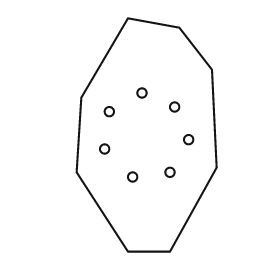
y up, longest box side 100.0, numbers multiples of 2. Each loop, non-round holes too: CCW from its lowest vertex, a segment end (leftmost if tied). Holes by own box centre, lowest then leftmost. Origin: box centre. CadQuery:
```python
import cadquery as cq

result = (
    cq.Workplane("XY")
    .moveTo(-8.0, -50.0)
    .lineTo(10.0, -50.0)
    .lineTo(30.0, -14.0)
    .lineTo(28.0, 28.0)
    .lineTo(14.0, 46.0)
    .lineTo(-8.0, 50.0)
    .lineTo(-28.0, 16.0)
    .lineTo(-30.0, -16.0)
    .close()
    .moveTo(-6.0, -18.0)
    .circle(2.0)
    .moveTo(10.0, -16.0)
    .circle(2.0)
    .moveTo(-18.0, -6.0)
    .circle(2.0)
    .moveTo(18.0, -2.0)
    .circle(2.0)
    .moveTo(-16.0, 10.0)
    .circle(2.0)
    .moveTo(12.0, 12.0)
    .circle(2.0)
    .moveTo(-2.0, 18.0)
    .circle(2.0)
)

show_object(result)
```